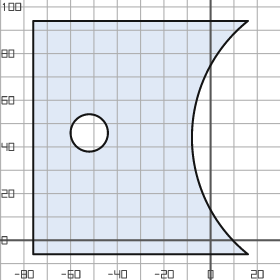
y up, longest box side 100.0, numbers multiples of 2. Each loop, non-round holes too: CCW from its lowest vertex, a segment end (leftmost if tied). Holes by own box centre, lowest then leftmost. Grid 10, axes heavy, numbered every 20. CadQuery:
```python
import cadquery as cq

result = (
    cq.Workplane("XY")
    .moveTo(-76.0, -6.0)
    .lineTo(16.0, -6.0)
    .threePointArc((-8.0, 44.0), (16.0, 94.0))
    .lineTo(-76.0, 94.0)
    .close()
    .moveTo(-52.0, 46.0)
    .circle(8.0)
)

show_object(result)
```